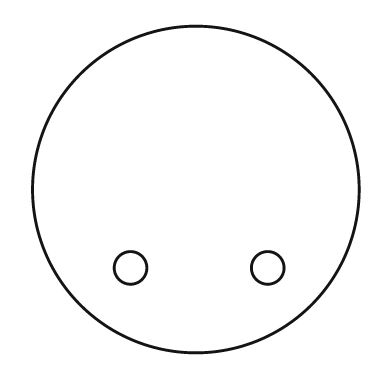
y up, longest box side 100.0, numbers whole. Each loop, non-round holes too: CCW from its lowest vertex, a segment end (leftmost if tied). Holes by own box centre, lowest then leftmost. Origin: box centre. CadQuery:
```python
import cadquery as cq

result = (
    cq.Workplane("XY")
    .moveTo(0.0, 0.0)
    .circle(50.0)
    .moveTo(-20.0, -24.0)
    .circle(5.0)
    .moveTo(22.0, -24.0)
    .circle(5.0)
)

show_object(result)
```